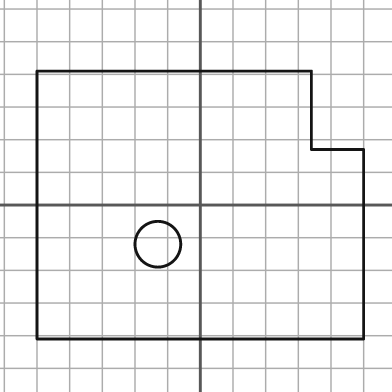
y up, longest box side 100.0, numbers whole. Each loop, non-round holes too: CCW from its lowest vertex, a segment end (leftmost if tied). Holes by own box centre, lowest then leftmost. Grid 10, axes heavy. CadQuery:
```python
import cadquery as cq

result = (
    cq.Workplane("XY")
    .moveTo(-50.0, -41.0)
    .lineTo(50.0, -41.0)
    .lineTo(50.0, 17.0)
    .lineTo(34.0, 17.0)
    .lineTo(34.0, 41.0)
    .lineTo(-50.0, 41.0)
    .close()
    .moveTo(-13.0, -12.0)
    .circle(7.0)
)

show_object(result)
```